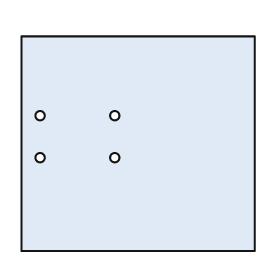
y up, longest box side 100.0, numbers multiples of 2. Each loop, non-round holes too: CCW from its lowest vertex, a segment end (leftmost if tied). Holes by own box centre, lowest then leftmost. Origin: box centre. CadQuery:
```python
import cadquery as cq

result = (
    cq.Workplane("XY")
    .moveTo(-50.0, -46.0)
    .lineTo(50.0, -46.0)
    .lineTo(50.0, 46.0)
    .lineTo(-50.0, 46.0)
    .close()
    .moveTo(-42.0, -6.0)
    .circle(2.0)
    .moveTo(-10.0, -6.0)
    .circle(2.0)
    .moveTo(-42.0, 12.0)
    .circle(2.0)
    .moveTo(-10.0, 12.0)
    .circle(2.0)
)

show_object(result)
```